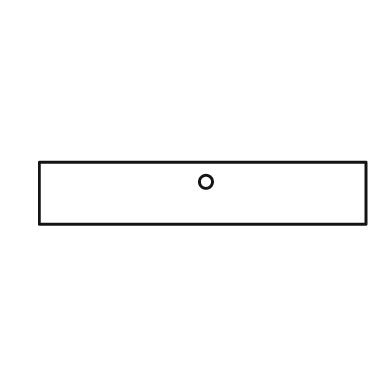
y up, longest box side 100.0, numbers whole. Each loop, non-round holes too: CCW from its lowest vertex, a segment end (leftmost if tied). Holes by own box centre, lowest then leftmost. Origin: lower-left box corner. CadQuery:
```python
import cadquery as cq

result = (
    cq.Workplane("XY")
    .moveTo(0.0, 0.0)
    .lineTo(100.0, 0.0)
    .lineTo(100.0, 19.0)
    .lineTo(0.0, 19.0)
    .close()
    .moveTo(51.0, 13.0)
    .circle(2.0)
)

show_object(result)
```